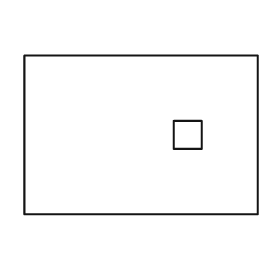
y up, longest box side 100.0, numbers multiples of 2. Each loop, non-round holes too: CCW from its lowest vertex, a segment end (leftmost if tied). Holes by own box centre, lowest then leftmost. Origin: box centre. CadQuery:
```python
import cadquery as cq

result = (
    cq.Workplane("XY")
    .moveTo(-50.0, -34.0)
    .lineTo(50.0, -34.0)
    .lineTo(50.0, 34.0)
    .lineTo(-50.0, 34.0)
    .close()
    .moveTo(14.0, -6.0)
    .lineTo(26.0, -6.0)
    .lineTo(26.0, 6.0)
    .lineTo(14.0, 6.0)
    .close()
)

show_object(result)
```